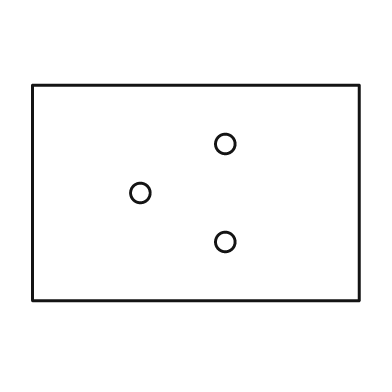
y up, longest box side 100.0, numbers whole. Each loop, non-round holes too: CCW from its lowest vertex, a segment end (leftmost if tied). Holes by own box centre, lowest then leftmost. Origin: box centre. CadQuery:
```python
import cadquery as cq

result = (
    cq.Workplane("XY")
    .moveTo(-50.0, -33.0)
    .lineTo(50.0, -33.0)
    .lineTo(50.0, 33.0)
    .lineTo(-50.0, 33.0)
    .close()
    .moveTo(9.0, -15.0)
    .circle(3.0)
    .moveTo(-17.0, 0.0)
    .circle(3.0)
    .moveTo(9.0, 15.0)
    .circle(3.0)
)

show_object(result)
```